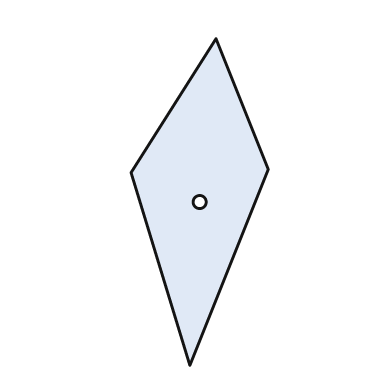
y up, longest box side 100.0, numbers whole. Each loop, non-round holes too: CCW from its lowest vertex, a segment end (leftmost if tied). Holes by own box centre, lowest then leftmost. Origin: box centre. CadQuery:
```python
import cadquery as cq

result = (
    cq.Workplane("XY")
    .moveTo(-3.0, -50.0)
    .lineTo(21.0, 10.0)
    .lineTo(5.0, 50.0)
    .lineTo(-21.0, 9.0)
    .close()
    .moveTo(0.0, 0.0)
    .circle(2.0)
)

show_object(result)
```